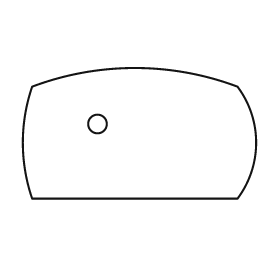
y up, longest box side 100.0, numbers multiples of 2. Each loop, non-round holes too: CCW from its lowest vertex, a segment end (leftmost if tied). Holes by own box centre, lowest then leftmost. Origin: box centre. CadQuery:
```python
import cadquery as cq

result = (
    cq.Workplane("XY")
    .moveTo(-46.0, -28.0)
    .lineTo(42.0, -28.0)
    .threePointArc((50.0, -4.0), (42.0, 20.0))
    .threePointArc((-2.0, 28.0), (-46.0, 20.0))
    .threePointArc((-50.0, -4.0), (-46.0, -28.0))
    .close()
    .moveTo(-18.0, 4.0)
    .circle(4.0)
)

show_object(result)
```